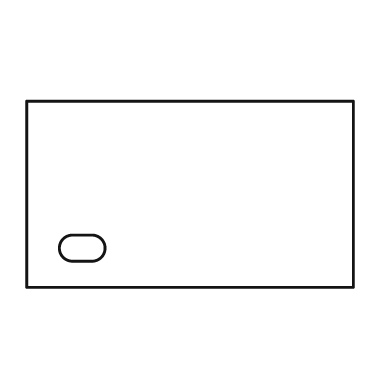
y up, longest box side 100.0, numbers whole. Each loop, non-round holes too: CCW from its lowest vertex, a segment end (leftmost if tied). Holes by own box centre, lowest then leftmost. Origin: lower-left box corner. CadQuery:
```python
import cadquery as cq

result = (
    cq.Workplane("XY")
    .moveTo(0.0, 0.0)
    .lineTo(100.0, 0.0)
    .lineTo(100.0, 57.0)
    .lineTo(0.0, 57.0)
    .close()
    .moveTo(14.0, 8.0)
    .lineTo(20.0, 8.0)
    .threePointArc((24.0, 12.0), (20.0, 16.0))
    .lineTo(14.0, 16.0)
    .threePointArc((10.0, 12.0), (14.0, 8.0))
    .close()
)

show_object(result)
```